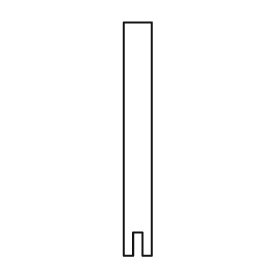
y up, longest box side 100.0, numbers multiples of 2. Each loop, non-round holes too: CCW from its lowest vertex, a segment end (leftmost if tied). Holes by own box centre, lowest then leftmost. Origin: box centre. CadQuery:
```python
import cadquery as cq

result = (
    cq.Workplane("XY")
    .moveTo(-6.0, -50.0)
    .lineTo(-2.0, -50.0)
    .lineTo(-2.0, -40.0)
    .lineTo(2.0, -40.0)
    .lineTo(2.0, -50.0)
    .lineTo(6.0, -50.0)
    .lineTo(6.0, 50.0)
    .lineTo(-6.0, 50.0)
    .close()
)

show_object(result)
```